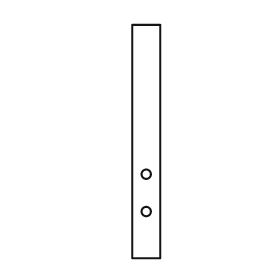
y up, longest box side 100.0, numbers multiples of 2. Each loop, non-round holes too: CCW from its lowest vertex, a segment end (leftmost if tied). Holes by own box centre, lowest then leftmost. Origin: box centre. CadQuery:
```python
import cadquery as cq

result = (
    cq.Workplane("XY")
    .moveTo(-6.0, -50.0)
    .lineTo(6.0, -50.0)
    .lineTo(6.0, 50.0)
    .lineTo(-6.0, 50.0)
    .close()
    .moveTo(0.0, -30.0)
    .circle(2.0)
    .moveTo(0.0, -14.0)
    .circle(2.0)
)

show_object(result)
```